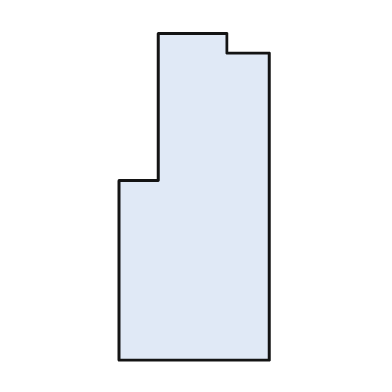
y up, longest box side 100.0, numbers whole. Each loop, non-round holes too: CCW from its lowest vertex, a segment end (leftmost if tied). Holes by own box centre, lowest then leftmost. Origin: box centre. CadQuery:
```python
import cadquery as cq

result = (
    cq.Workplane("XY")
    .moveTo(-23.0, -50.0)
    .lineTo(23.0, -50.0)
    .lineTo(23.0, 44.0)
    .lineTo(10.0, 44.0)
    .lineTo(10.0, 50.0)
    .lineTo(-11.0, 50.0)
    .lineTo(-11.0, 5.0)
    .lineTo(-23.0, 5.0)
    .close()
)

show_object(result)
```